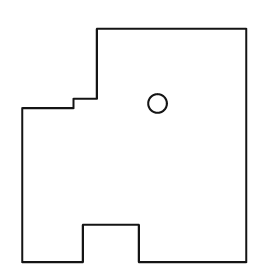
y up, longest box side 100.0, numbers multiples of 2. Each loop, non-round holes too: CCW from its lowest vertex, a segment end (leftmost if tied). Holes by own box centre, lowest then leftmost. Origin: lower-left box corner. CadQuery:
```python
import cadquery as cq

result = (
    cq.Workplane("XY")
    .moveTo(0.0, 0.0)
    .lineTo(26.0, 0.0)
    .lineTo(26.0, 16.0)
    .lineTo(50.0, 16.0)
    .lineTo(50.0, 0.0)
    .lineTo(96.0, 0.0)
    .lineTo(96.0, 100.0)
    .lineTo(32.0, 100.0)
    .lineTo(32.0, 70.0)
    .lineTo(22.0, 70.0)
    .lineTo(22.0, 66.0)
    .lineTo(0.0, 66.0)
    .close()
    .moveTo(58.0, 68.0)
    .circle(4.0)
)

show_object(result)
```